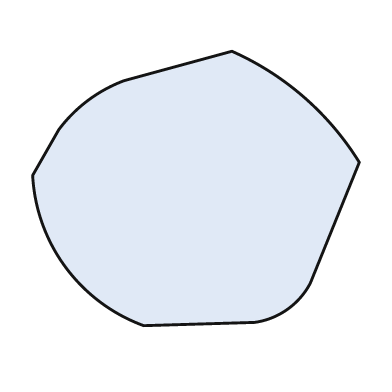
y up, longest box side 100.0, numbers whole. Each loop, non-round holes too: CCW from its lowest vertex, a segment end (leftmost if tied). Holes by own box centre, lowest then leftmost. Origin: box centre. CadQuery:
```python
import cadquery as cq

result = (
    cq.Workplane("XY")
    .moveTo(-16.0, -42.0)
    .lineTo(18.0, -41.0)
    .threePointArc((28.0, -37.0), (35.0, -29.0))
    .lineTo(50.0, 8.0)
    .threePointArc((33.0, 28.0), (11.0, 42.0))
    .lineTo(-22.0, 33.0)
    .threePointArc((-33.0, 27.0), (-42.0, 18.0))
    .lineTo(-50.0, 4.0)
    .threePointArc((-40.0, -24.0), (-16.0, -42.0))
    .close()
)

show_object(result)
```